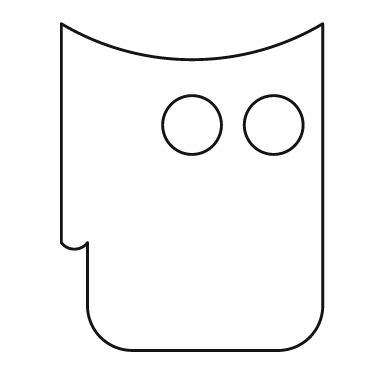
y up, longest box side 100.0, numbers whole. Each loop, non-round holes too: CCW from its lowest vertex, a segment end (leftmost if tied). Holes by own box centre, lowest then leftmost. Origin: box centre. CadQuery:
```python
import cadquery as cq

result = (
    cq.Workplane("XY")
    .moveTo(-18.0, -50.0)
    .lineTo(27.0, -50.0)
    .threePointArc((36.0, -46.0), (40.0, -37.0))
    .lineTo(40.0, 50.0)
    .threePointArc((0.0, 39.0), (-40.0, 50.0))
    .lineTo(-40.0, -17.0)
    .threePointArc((-36.0, -19.0), (-32.0, -17.0))
    .lineTo(-32.0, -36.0)
    .threePointArc((-28.0, -46.0), (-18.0, -50.0))
    .close()
    .moveTo(0.0, 19.0)
    .circle(9.0)
    .moveTo(25.0, 19.0)
    .circle(9.0)
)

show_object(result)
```